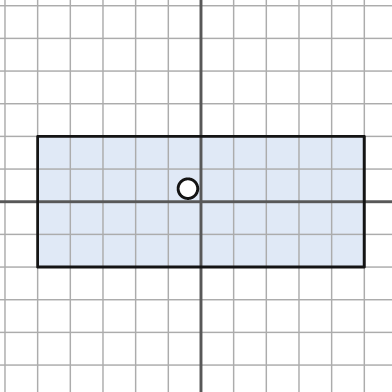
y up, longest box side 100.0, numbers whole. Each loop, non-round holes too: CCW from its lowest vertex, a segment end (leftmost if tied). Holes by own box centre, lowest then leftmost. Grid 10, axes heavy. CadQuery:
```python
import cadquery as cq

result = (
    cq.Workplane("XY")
    .moveTo(-50.0, -20.0)
    .lineTo(50.0, -20.0)
    .lineTo(50.0, 20.0)
    .lineTo(-50.0, 20.0)
    .close()
    .moveTo(-4.0, 4.0)
    .circle(3.0)
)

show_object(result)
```